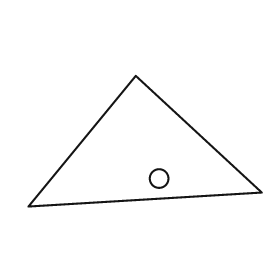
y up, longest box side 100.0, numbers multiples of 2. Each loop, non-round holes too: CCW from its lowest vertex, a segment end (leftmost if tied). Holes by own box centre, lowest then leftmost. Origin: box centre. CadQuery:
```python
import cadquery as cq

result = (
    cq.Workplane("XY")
    .moveTo(-50.0, -28.0)
    .lineTo(50.0, -22.0)
    .lineTo(-4.0, 28.0)
    .close()
    .moveTo(6.0, -16.0)
    .circle(4.0)
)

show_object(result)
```